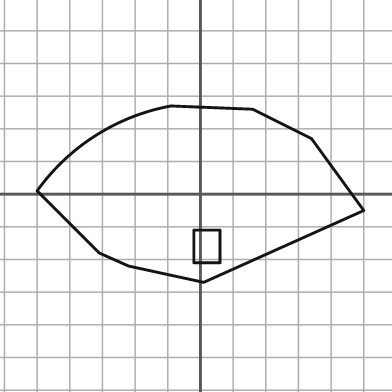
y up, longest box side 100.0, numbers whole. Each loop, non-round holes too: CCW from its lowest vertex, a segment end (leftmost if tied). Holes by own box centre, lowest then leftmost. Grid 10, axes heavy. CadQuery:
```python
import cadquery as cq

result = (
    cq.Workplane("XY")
    .moveTo(1.0, -27.0)
    .lineTo(50.0, -5.0)
    .lineTo(34.0, 17.0)
    .lineTo(16.0, 26.0)
    .lineTo(-9.0, 27.0)
    .threePointArc((-32.0, 18.0), (-50.0, 1.0))
    .lineTo(-31.0, -18.0)
    .lineTo(-22.0, -22.0)
    .close()
    .moveTo(-2.0, -21.0)
    .lineTo(6.0, -21.0)
    .lineTo(6.0, -11.0)
    .lineTo(-2.0, -11.0)
    .close()
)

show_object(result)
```